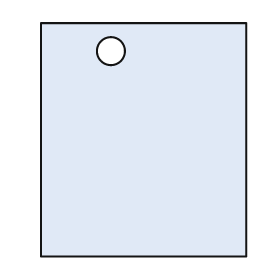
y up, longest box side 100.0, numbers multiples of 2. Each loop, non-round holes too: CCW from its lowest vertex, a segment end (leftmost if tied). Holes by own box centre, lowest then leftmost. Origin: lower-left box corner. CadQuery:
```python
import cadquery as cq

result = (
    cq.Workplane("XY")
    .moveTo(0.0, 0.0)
    .lineTo(88.0, 0.0)
    .lineTo(88.0, 100.0)
    .lineTo(0.0, 100.0)
    .close()
    .moveTo(30.0, 88.0)
    .circle(6.0)
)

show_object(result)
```